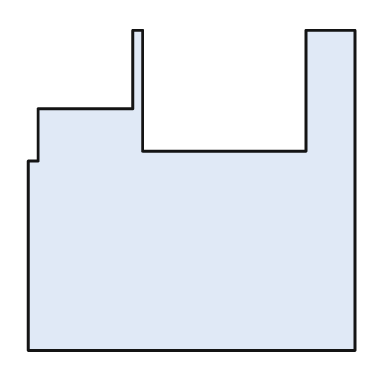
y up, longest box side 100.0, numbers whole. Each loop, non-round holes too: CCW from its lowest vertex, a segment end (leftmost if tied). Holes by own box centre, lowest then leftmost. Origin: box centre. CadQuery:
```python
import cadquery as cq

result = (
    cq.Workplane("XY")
    .moveTo(-50.0, -49.0)
    .lineTo(50.0, -49.0)
    .lineTo(50.0, 49.0)
    .lineTo(35.0, 49.0)
    .lineTo(35.0, 12.0)
    .lineTo(-15.0, 12.0)
    .lineTo(-15.0, 49.0)
    .lineTo(-18.0, 49.0)
    .lineTo(-18.0, 25.0)
    .lineTo(-47.0, 25.0)
    .lineTo(-47.0, 9.0)
    .lineTo(-50.0, 9.0)
    .close()
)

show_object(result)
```